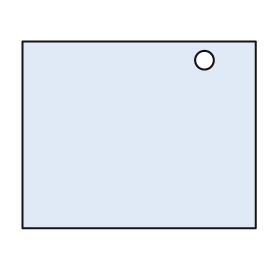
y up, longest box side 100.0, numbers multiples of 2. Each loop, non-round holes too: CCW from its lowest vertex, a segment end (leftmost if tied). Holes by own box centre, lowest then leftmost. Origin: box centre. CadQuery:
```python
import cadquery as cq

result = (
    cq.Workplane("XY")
    .moveTo(-50.0, -40.0)
    .lineTo(50.0, -40.0)
    .lineTo(50.0, 40.0)
    .lineTo(-50.0, 40.0)
    .close()
    .moveTo(28.0, 32.0)
    .circle(4.0)
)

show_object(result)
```